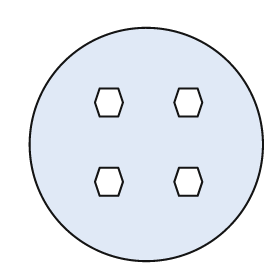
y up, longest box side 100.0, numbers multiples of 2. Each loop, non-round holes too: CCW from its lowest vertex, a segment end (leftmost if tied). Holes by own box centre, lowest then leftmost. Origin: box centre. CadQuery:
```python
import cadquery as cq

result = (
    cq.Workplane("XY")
    .moveTo(0.0, 0.0)
    .circle(50.0)
    .moveTo(-20.0, -22.0)
    .lineTo(-12.0, -22.0)
    .lineTo(-10.0, -16.0)
    .lineTo(-12.0, -10.0)
    .lineTo(-20.0, -10.0)
    .lineTo(-22.0, -16.0)
    .close()
    .moveTo(14.0, -22.0)
    .lineTo(22.0, -22.0)
    .lineTo(24.0, -16.0)
    .lineTo(22.0, -10.0)
    .lineTo(14.0, -10.0)
    .lineTo(12.0, -16.0)
    .close()
    .moveTo(-20.0, 12.0)
    .lineTo(-12.0, 12.0)
    .lineTo(-10.0, 18.0)
    .lineTo(-12.0, 24.0)
    .lineTo(-20.0, 24.0)
    .lineTo(-22.0, 18.0)
    .close()
    .moveTo(14.0, 12.0)
    .lineTo(22.0, 12.0)
    .lineTo(24.0, 18.0)
    .lineTo(22.0, 24.0)
    .lineTo(14.0, 24.0)
    .lineTo(12.0, 18.0)
    .close()
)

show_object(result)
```